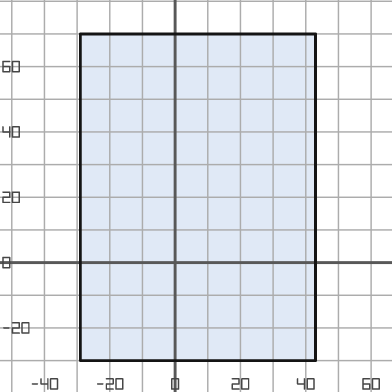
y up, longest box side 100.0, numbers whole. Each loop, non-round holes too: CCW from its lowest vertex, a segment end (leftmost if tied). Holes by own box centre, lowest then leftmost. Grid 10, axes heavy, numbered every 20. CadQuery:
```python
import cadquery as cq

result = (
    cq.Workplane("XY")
    .moveTo(-29.0, -30.0)
    .lineTo(43.0, -30.0)
    .lineTo(43.0, 70.0)
    .lineTo(-29.0, 70.0)
    .close()
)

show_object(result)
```